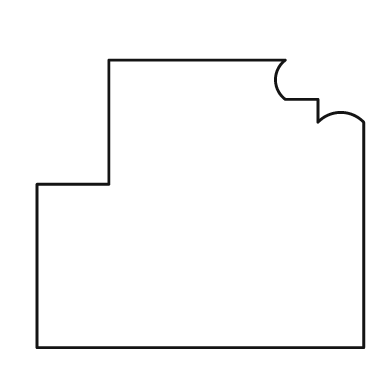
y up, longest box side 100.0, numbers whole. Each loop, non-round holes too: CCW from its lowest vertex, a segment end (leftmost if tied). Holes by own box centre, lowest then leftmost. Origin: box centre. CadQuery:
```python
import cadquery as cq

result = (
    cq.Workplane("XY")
    .moveTo(-50.0, -44.0)
    .lineTo(50.0, -44.0)
    .lineTo(50.0, 25.0)
    .threePointArc((43.0, 28.0), (36.0, 25.0))
    .lineTo(36.0, 32.0)
    .lineTo(26.0, 32.0)
    .threePointArc((23.0, 38.0), (26.0, 44.0))
    .lineTo(-28.0, 44.0)
    .lineTo(-28.0, 6.0)
    .lineTo(-50.0, 6.0)
    .close()
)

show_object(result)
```